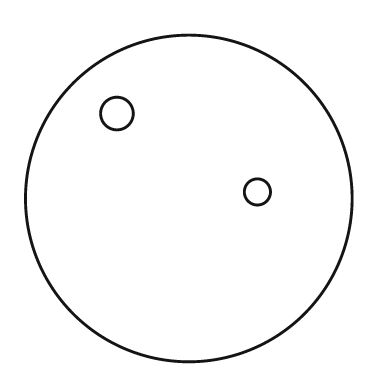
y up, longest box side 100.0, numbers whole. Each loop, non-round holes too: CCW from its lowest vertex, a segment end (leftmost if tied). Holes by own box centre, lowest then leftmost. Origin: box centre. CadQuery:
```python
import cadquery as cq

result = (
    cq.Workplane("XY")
    .moveTo(0.0, 0.0)
    .circle(50.0)
    .moveTo(21.0, 2.0)
    .circle(4.0)
    .moveTo(-22.0, 26.0)
    .circle(5.0)
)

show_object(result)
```